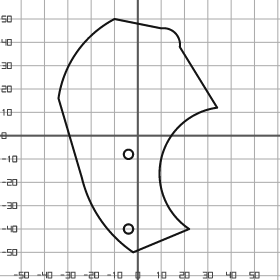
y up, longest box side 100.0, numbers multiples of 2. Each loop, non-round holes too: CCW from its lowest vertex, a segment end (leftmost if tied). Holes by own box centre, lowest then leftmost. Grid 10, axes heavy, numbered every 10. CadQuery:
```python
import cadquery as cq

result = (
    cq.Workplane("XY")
    .moveTo(-2.0, -50.0)
    .lineTo(22.0, -40.0)
    .threePointArc((10.0, -10.0), (34.0, 12.0))
    .lineTo(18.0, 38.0)
    .threePointArc((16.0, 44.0), (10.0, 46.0))
    .lineTo(-10.0, 50.0)
    .threePointArc((-26.0, 36.0), (-34.0, 16.0))
    .lineTo(-24.0, -18.0)
    .threePointArc((-16.0, -36.0), (-2.0, -50.0))
    .close()
    .moveTo(-4.0, -40.0)
    .circle(2.0)
    .moveTo(-4.0, -8.0)
    .circle(2.0)
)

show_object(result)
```